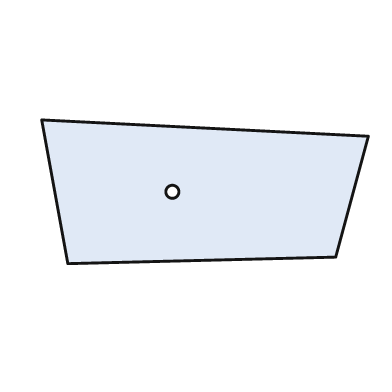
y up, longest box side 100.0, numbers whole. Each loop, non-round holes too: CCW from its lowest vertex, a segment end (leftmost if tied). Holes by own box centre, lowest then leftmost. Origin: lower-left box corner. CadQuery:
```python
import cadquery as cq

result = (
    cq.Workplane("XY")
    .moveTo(8.0, 0.0)
    .lineTo(90.0, 2.0)
    .lineTo(100.0, 39.0)
    .lineTo(0.0, 44.0)
    .close()
    .moveTo(40.0, 22.0)
    .circle(2.0)
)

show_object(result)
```